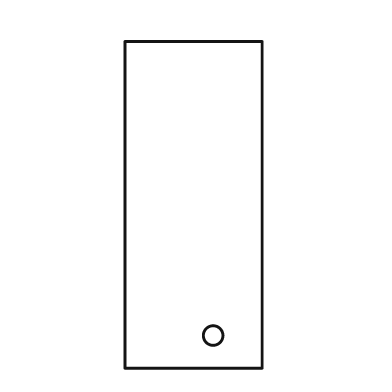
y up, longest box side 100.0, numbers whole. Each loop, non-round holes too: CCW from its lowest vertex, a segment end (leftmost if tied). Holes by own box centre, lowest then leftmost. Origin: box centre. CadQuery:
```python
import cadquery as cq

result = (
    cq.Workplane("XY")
    .moveTo(-21.0, -50.0)
    .lineTo(21.0, -50.0)
    .lineTo(21.0, 50.0)
    .lineTo(-21.0, 50.0)
    .close()
    .moveTo(6.0, -40.0)
    .circle(3.0)
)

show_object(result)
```